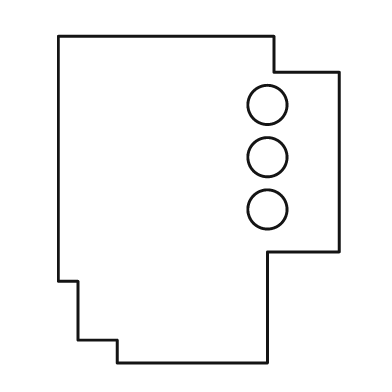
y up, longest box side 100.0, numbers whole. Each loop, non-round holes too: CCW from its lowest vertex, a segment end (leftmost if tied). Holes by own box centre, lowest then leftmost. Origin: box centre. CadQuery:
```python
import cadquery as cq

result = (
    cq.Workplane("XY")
    .moveTo(-25.0, -50.0)
    .lineTo(21.0, -50.0)
    .lineTo(21.0, -16.0)
    .lineTo(43.0, -16.0)
    .lineTo(43.0, 39.0)
    .lineTo(23.0, 39.0)
    .lineTo(23.0, 50.0)
    .lineTo(-43.0, 50.0)
    .lineTo(-43.0, -25.0)
    .lineTo(-37.0, -25.0)
    .lineTo(-37.0, -43.0)
    .lineTo(-25.0, -43.0)
    .close()
    .moveTo(21.0, -3.0)
    .circle(6.0)
    .moveTo(21.0, 13.0)
    .circle(6.0)
    .moveTo(21.0, 29.0)
    .circle(6.0)
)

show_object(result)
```